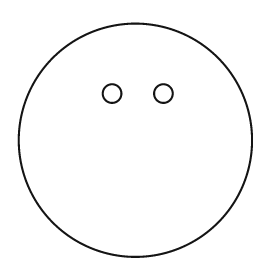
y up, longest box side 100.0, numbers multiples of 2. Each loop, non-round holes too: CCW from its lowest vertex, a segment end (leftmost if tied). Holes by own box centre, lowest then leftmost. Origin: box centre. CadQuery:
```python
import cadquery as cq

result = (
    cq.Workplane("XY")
    .moveTo(0.0, 0.0)
    .circle(50.0)
    .moveTo(-10.0, 20.0)
    .circle(4.0)
    .moveTo(12.0, 20.0)
    .circle(4.0)
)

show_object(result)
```